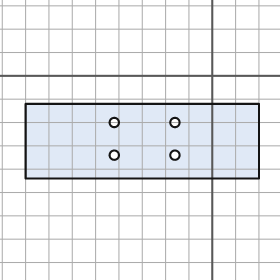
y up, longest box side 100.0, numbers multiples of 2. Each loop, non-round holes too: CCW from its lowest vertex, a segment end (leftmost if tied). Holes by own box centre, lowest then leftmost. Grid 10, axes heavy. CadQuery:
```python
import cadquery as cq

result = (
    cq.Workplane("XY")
    .moveTo(-80.0, -44.0)
    .lineTo(20.0, -44.0)
    .lineTo(20.0, -12.0)
    .lineTo(-80.0, -12.0)
    .close()
    .moveTo(-42.0, -34.0)
    .circle(2.0)
    .moveTo(-16.0, -34.0)
    .circle(2.0)
    .moveTo(-42.0, -20.0)
    .circle(2.0)
    .moveTo(-16.0, -20.0)
    .circle(2.0)
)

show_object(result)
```